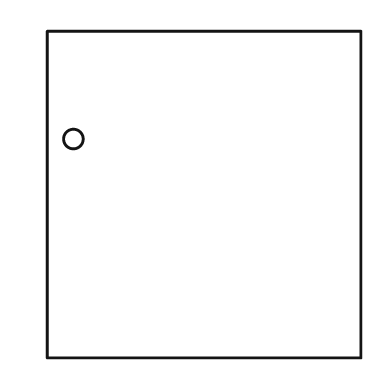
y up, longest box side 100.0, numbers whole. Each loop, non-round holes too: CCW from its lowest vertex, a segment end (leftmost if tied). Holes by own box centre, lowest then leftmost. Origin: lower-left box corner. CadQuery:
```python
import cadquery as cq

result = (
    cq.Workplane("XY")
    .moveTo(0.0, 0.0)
    .lineTo(96.0, 0.0)
    .lineTo(96.0, 100.0)
    .lineTo(0.0, 100.0)
    .close()
    .moveTo(8.0, 67.0)
    .circle(3.0)
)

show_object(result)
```